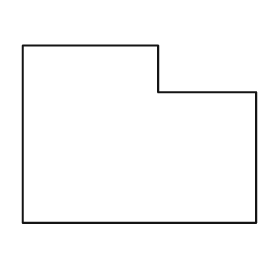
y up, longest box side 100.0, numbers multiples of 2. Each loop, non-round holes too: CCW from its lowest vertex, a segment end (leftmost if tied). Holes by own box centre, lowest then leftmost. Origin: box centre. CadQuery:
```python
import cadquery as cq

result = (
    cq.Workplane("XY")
    .moveTo(-50.0, -38.0)
    .lineTo(50.0, -38.0)
    .lineTo(50.0, 18.0)
    .lineTo(8.0, 18.0)
    .lineTo(8.0, 38.0)
    .lineTo(-50.0, 38.0)
    .close()
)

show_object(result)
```